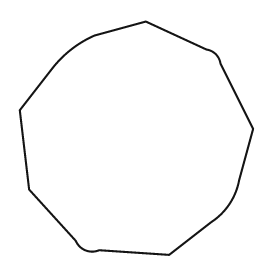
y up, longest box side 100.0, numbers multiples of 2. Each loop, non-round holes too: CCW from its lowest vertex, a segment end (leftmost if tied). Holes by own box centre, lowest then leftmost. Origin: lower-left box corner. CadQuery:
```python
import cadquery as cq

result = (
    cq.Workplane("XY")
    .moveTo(64.0, 0.0)
    .lineTo(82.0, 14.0)
    .threePointArc((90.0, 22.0), (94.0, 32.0))
    .lineTo(100.0, 54.0)
    .lineTo(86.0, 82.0)
    .threePointArc((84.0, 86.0), (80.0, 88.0))
    .lineTo(54.0, 100.0)
    .lineTo(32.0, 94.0)
    .threePointArc((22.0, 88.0), (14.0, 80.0))
    .lineTo(0.0, 62.0)
    .lineTo(4.0, 28.0)
    .lineTo(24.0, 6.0)
    .threePointArc((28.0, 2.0), (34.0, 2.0))
    .close()
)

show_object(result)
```